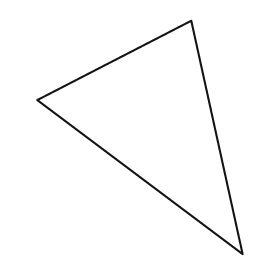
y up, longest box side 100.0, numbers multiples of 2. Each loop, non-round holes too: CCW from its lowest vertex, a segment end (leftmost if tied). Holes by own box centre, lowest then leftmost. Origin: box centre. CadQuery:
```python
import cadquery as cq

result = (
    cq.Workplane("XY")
    .moveTo(44.0, -50.0)
    .lineTo(22.0, 50.0)
    .lineTo(-44.0, 16.0)
    .close()
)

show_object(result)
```